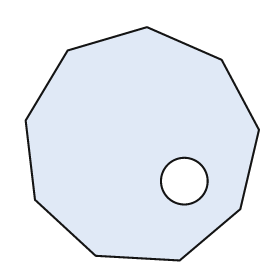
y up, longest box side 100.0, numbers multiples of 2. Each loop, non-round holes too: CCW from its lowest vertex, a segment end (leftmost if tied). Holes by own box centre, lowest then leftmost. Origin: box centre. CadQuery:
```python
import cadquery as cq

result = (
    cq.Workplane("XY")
    .moveTo(16.0, -50.0)
    .lineTo(42.0, -28.0)
    .lineTo(50.0, 6.0)
    .lineTo(34.0, 36.0)
    .lineTo(2.0, 50.0)
    .lineTo(-32.0, 40.0)
    .lineTo(-50.0, 10.0)
    .lineTo(-46.0, -24.0)
    .lineTo(-20.0, -48.0)
    .close()
    .moveTo(18.0, -16.0)
    .circle(10.0)
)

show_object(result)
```